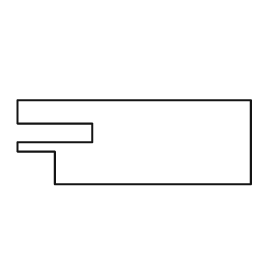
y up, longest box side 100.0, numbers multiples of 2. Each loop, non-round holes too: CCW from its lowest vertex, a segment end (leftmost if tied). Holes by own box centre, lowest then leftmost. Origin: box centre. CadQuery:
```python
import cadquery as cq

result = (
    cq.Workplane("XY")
    .moveTo(-34.0, -18.0)
    .lineTo(50.0, -18.0)
    .lineTo(50.0, 18.0)
    .lineTo(-50.0, 18.0)
    .lineTo(-50.0, 8.0)
    .lineTo(-18.0, 8.0)
    .lineTo(-18.0, 0.0)
    .lineTo(-50.0, 0.0)
    .lineTo(-50.0, -4.0)
    .lineTo(-34.0, -4.0)
    .close()
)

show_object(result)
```